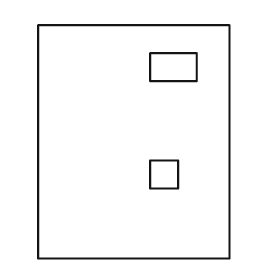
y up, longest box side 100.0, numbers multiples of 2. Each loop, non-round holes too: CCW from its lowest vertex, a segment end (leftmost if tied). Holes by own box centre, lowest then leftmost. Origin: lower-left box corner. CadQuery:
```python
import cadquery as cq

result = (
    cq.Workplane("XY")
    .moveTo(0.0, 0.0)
    .lineTo(82.0, 0.0)
    .lineTo(82.0, 100.0)
    .lineTo(0.0, 100.0)
    .close()
    .moveTo(48.0, 30.0)
    .lineTo(60.0, 30.0)
    .lineTo(60.0, 42.0)
    .lineTo(48.0, 42.0)
    .close()
    .moveTo(48.0, 76.0)
    .lineTo(68.0, 76.0)
    .lineTo(68.0, 88.0)
    .lineTo(48.0, 88.0)
    .close()
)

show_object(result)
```